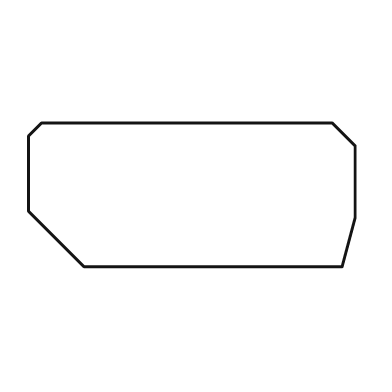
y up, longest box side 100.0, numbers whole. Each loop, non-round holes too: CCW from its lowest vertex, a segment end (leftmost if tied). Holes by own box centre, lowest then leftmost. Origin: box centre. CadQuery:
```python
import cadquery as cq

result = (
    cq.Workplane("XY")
    .moveTo(-33.0, -22.0)
    .lineTo(46.0, -22.0)
    .lineTo(50.0, -7.0)
    .lineTo(50.0, 15.0)
    .lineTo(43.0, 22.0)
    .lineTo(-46.0, 22.0)
    .lineTo(-50.0, 18.0)
    .lineTo(-50.0, -5.0)
    .close()
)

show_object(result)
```